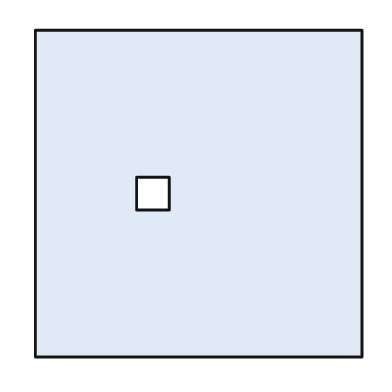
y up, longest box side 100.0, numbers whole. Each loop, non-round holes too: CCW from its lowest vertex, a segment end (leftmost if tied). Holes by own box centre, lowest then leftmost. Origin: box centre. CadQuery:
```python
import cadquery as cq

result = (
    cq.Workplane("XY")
    .moveTo(-50.0, -50.0)
    .lineTo(50.0, -50.0)
    .lineTo(50.0, 50.0)
    .lineTo(-50.0, 50.0)
    .close()
    .moveTo(-19.0, -5.0)
    .lineTo(-9.0, -5.0)
    .lineTo(-9.0, 5.0)
    .lineTo(-19.0, 5.0)
    .close()
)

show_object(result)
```